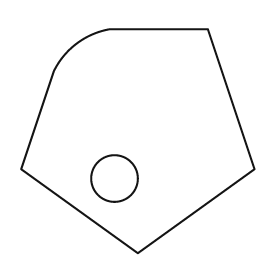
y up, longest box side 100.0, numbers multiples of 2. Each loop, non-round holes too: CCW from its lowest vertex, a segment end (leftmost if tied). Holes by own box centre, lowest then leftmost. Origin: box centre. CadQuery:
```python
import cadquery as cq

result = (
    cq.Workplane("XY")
    .moveTo(0.0, -48.0)
    .lineTo(50.0, -12.0)
    .lineTo(30.0, 48.0)
    .lineTo(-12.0, 48.0)
    .threePointArc((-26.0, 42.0), (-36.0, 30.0))
    .lineTo(-50.0, -12.0)
    .close()
    .moveTo(-10.0, -16.0)
    .circle(10.0)
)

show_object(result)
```